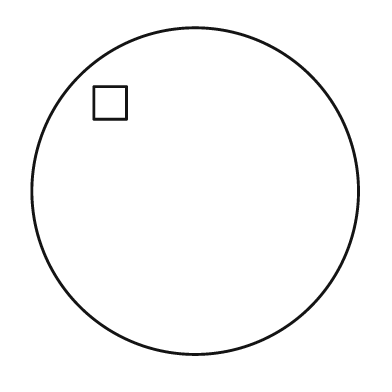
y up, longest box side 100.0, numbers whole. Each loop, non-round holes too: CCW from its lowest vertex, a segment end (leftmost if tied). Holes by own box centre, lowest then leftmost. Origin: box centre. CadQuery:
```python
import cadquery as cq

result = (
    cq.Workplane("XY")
    .moveTo(0.0, 0.0)
    .circle(50.0)
    .moveTo(-31.0, 22.0)
    .lineTo(-21.0, 22.0)
    .lineTo(-21.0, 32.0)
    .lineTo(-31.0, 32.0)
    .close()
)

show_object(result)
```